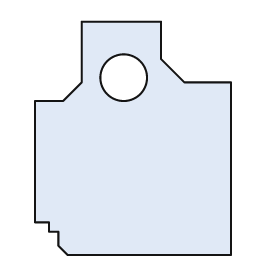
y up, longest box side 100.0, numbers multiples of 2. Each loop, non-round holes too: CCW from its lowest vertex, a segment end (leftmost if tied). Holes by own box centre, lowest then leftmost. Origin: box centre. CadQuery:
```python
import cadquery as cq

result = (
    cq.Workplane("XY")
    .moveTo(-28.0, -50.0)
    .lineTo(42.0, -50.0)
    .lineTo(42.0, 24.0)
    .lineTo(22.0, 24.0)
    .lineTo(12.0, 34.0)
    .lineTo(12.0, 50.0)
    .lineTo(-22.0, 50.0)
    .lineTo(-22.0, 24.0)
    .lineTo(-30.0, 16.0)
    .lineTo(-42.0, 16.0)
    .lineTo(-42.0, -36.0)
    .lineTo(-36.0, -36.0)
    .lineTo(-36.0, -40.0)
    .lineTo(-32.0, -40.0)
    .lineTo(-32.0, -46.0)
    .close()
    .moveTo(-4.0, 26.0)
    .circle(10.0)
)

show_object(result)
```